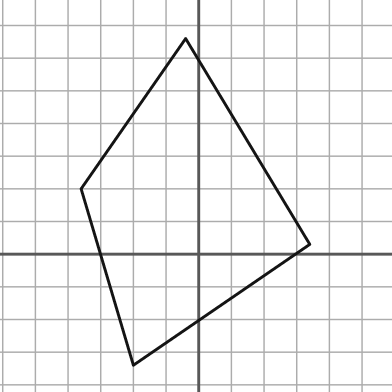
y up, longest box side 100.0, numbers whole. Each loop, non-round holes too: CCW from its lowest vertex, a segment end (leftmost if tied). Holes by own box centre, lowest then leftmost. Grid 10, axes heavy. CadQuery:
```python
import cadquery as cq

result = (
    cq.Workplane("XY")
    .moveTo(-20.0, -34.0)
    .lineTo(34.0, 3.0)
    .lineTo(-4.0, 66.0)
    .lineTo(-36.0, 20.0)
    .close()
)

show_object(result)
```